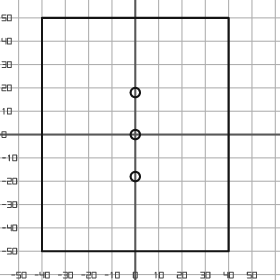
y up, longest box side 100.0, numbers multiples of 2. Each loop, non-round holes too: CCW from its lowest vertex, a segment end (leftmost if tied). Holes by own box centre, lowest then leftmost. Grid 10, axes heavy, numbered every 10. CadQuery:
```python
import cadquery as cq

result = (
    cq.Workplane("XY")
    .moveTo(-40.0, -50.0)
    .lineTo(40.0, -50.0)
    .lineTo(40.0, 50.0)
    .lineTo(-40.0, 50.0)
    .close()
    .moveTo(0.0, -18.0)
    .circle(2.0)
    .moveTo(0.0, 0.0)
    .circle(2.0)
    .moveTo(0.0, 18.0)
    .circle(2.0)
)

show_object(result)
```